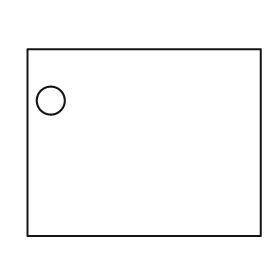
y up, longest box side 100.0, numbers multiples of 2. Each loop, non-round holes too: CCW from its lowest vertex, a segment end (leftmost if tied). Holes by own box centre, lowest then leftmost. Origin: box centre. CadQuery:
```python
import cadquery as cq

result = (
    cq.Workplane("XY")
    .moveTo(-50.0, -40.0)
    .lineTo(50.0, -40.0)
    .lineTo(50.0, 40.0)
    .lineTo(-50.0, 40.0)
    .close()
    .moveTo(-40.0, 18.0)
    .circle(6.0)
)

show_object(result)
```